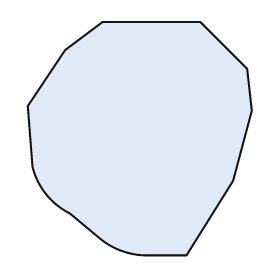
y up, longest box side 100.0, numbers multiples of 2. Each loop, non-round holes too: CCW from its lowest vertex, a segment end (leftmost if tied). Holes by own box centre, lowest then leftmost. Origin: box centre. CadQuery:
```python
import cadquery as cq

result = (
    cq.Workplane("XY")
    .moveTo(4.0, -50.0)
    .lineTo(20.0, -50.0)
    .lineTo(40.0, -18.0)
    .lineTo(48.0, 12.0)
    .lineTo(46.0, 30.0)
    .lineTo(26.0, 50.0)
    .lineTo(-16.0, 50.0)
    .lineTo(-32.0, 38.0)
    .lineTo(-48.0, 14.0)
    .lineTo(-46.0, -12.0)
    .threePointArc((-40.0, -24.0), (-30.0, -32.0))
    .lineTo(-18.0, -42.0)
    .threePointArc((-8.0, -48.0), (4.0, -50.0))
    .close()
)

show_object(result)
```